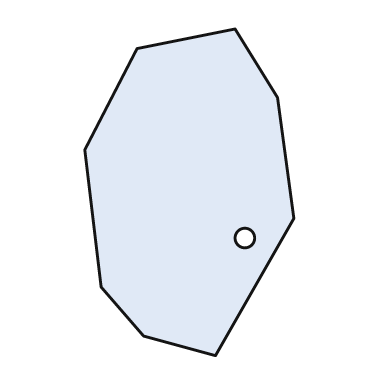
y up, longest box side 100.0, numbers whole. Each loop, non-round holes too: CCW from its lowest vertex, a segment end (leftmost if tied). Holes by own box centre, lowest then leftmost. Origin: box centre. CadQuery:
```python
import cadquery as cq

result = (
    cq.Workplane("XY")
    .moveTo(8.0, -50.0)
    .lineTo(32.0, -8.0)
    .lineTo(27.0, 29.0)
    .lineTo(14.0, 50.0)
    .lineTo(-16.0, 44.0)
    .lineTo(-32.0, 13.0)
    .lineTo(-27.0, -29.0)
    .lineTo(-14.0, -44.0)
    .close()
    .moveTo(17.0, -14.0)
    .circle(3.0)
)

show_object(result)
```